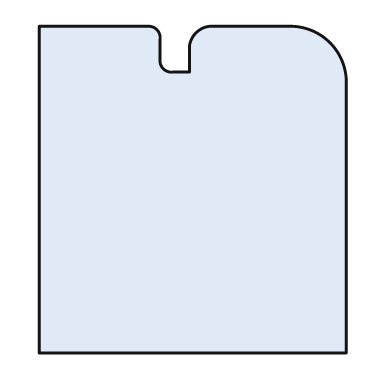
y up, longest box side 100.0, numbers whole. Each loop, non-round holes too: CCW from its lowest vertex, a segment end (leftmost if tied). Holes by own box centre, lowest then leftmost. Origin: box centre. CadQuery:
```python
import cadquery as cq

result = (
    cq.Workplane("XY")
    .moveTo(-47.0, -50.0)
    .lineTo(47.0, -50.0)
    .lineTo(47.0, 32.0)
    .threePointArc((42.0, 45.0), (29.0, 50.0))
    .lineTo(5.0, 50.0)
    .threePointArc((1.0, 48.0), (-1.0, 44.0))
    .lineTo(-1.0, 36.0)
    .lineTo(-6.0, 36.0)
    .threePointArc((-9.0, 37.0), (-10.0, 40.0))
    .lineTo(-10.0, 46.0)
    .threePointArc((-11.0, 49.0), (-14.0, 50.0))
    .lineTo(-47.0, 50.0)
    .close()
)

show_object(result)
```